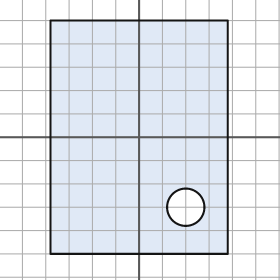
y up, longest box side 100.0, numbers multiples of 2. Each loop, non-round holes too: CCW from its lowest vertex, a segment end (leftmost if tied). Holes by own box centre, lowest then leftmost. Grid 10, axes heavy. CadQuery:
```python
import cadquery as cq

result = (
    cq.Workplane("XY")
    .moveTo(-38.0, -50.0)
    .lineTo(38.0, -50.0)
    .lineTo(38.0, 50.0)
    .lineTo(-38.0, 50.0)
    .close()
    .moveTo(20.0, -30.0)
    .circle(8.0)
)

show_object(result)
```